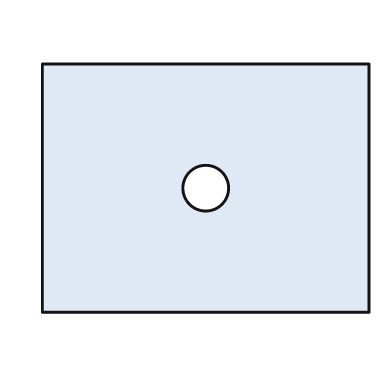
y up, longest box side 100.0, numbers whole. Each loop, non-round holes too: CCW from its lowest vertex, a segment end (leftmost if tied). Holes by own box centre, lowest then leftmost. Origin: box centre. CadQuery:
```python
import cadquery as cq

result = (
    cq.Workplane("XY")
    .moveTo(-50.0, -38.0)
    .lineTo(50.0, -38.0)
    .lineTo(50.0, 38.0)
    .lineTo(-50.0, 38.0)
    .close()
    .moveTo(0.0, 0.0)
    .circle(7.0)
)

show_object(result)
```